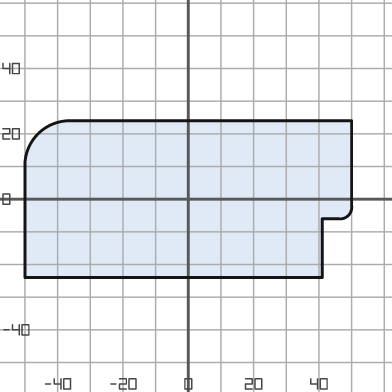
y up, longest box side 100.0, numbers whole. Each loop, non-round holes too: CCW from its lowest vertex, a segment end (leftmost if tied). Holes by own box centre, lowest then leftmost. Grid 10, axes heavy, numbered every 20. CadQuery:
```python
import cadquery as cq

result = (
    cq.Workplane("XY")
    .moveTo(-50.0, -24.0)
    .lineTo(41.0, -24.0)
    .lineTo(41.0, -6.0)
    .lineTo(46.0, -6.0)
    .threePointArc((49.0, -5.0), (50.0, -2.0))
    .lineTo(50.0, 24.0)
    .lineTo(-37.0, 24.0)
    .threePointArc((-46.0, 20.0), (-50.0, 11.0))
    .close()
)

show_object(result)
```